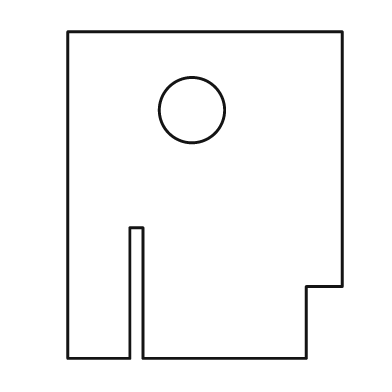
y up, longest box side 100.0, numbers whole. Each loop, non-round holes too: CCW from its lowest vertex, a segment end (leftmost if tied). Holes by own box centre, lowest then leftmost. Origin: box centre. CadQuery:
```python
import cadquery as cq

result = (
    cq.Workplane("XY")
    .moveTo(-42.0, -50.0)
    .lineTo(-23.0, -50.0)
    .lineTo(-23.0, -10.0)
    .lineTo(-19.0, -10.0)
    .lineTo(-19.0, -50.0)
    .lineTo(31.0, -50.0)
    .lineTo(31.0, -28.0)
    .lineTo(42.0, -28.0)
    .lineTo(42.0, 50.0)
    .lineTo(-42.0, 50.0)
    .close()
    .moveTo(-4.0, 26.0)
    .circle(10.0)
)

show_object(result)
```